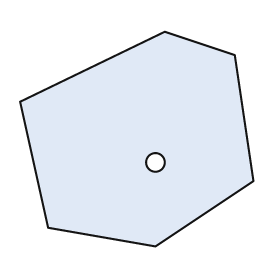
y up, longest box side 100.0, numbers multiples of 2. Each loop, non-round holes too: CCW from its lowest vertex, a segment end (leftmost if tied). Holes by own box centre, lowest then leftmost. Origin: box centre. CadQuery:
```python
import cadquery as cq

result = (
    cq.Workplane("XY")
    .moveTo(8.0, -46.0)
    .lineTo(50.0, -18.0)
    .lineTo(42.0, 36.0)
    .lineTo(12.0, 46.0)
    .lineTo(-50.0, 16.0)
    .lineTo(-38.0, -38.0)
    .close()
    .moveTo(8.0, -10.0)
    .circle(4.0)
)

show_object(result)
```